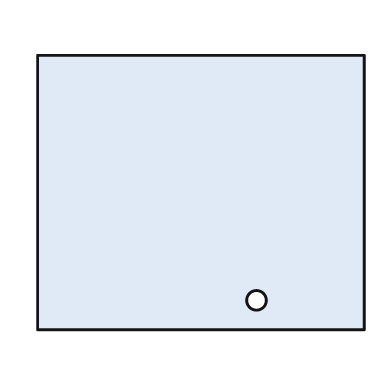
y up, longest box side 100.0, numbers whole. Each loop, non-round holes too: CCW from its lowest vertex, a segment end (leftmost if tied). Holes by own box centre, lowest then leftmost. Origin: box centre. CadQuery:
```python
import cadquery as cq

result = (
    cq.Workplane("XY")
    .moveTo(-50.0, -42.0)
    .lineTo(50.0, -42.0)
    .lineTo(50.0, 42.0)
    .lineTo(-50.0, 42.0)
    .close()
    .moveTo(17.0, -33.0)
    .circle(3.0)
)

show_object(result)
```